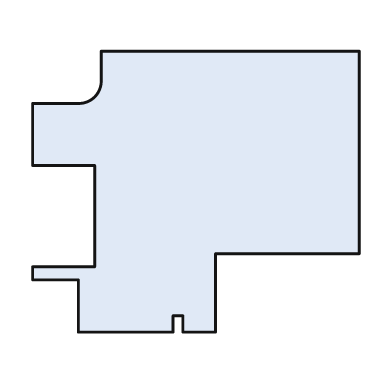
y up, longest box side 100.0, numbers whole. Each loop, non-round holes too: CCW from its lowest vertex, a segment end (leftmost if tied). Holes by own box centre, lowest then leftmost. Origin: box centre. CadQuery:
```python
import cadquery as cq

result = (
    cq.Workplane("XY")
    .moveTo(-36.0, -43.0)
    .lineTo(-7.0, -43.0)
    .lineTo(-7.0, -38.0)
    .lineTo(-4.0, -38.0)
    .lineTo(-4.0, -43.0)
    .lineTo(6.0, -43.0)
    .lineTo(6.0, -19.0)
    .lineTo(50.0, -19.0)
    .lineTo(50.0, 43.0)
    .lineTo(-29.0, 43.0)
    .lineTo(-29.0, 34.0)
    .threePointArc((-31.0, 29.0), (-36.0, 27.0))
    .lineTo(-50.0, 27.0)
    .lineTo(-50.0, 8.0)
    .lineTo(-31.0, 8.0)
    .lineTo(-31.0, -23.0)
    .lineTo(-50.0, -23.0)
    .lineTo(-50.0, -27.0)
    .lineTo(-36.0, -27.0)
    .close()
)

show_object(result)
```